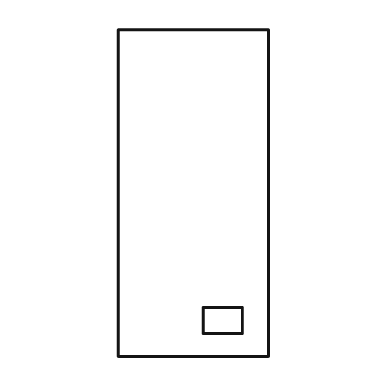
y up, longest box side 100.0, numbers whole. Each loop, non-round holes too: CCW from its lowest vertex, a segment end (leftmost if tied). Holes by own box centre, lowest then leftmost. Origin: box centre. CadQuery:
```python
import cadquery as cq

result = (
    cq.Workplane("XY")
    .moveTo(-23.0, -50.0)
    .lineTo(23.0, -50.0)
    .lineTo(23.0, 50.0)
    .lineTo(-23.0, 50.0)
    .close()
    .moveTo(3.0, -43.0)
    .lineTo(15.0, -43.0)
    .lineTo(15.0, -35.0)
    .lineTo(3.0, -35.0)
    .close()
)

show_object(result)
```